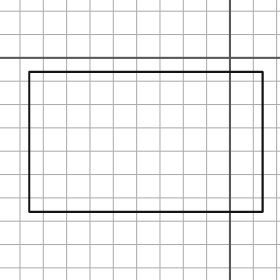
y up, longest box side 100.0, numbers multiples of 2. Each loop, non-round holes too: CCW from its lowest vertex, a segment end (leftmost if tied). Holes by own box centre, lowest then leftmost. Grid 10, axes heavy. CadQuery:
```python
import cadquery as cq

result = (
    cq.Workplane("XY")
    .moveTo(-86.0, -66.0)
    .lineTo(14.0, -66.0)
    .lineTo(14.0, -6.0)
    .lineTo(-86.0, -6.0)
    .close()
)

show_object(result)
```